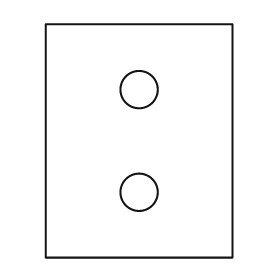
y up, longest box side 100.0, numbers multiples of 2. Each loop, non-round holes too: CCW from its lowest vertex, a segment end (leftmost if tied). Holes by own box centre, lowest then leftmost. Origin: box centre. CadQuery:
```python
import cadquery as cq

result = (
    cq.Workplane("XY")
    .moveTo(-40.0, -50.0)
    .lineTo(40.0, -50.0)
    .lineTo(40.0, 50.0)
    .lineTo(-40.0, 50.0)
    .close()
    .moveTo(0.0, -22.0)
    .circle(8.0)
    .moveTo(0.0, 22.0)
    .circle(8.0)
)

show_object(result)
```